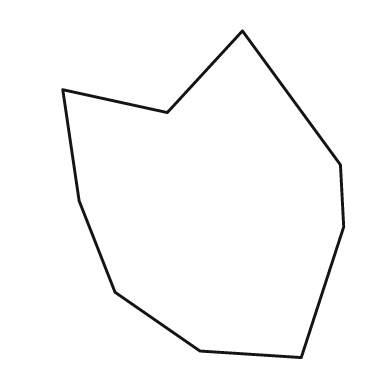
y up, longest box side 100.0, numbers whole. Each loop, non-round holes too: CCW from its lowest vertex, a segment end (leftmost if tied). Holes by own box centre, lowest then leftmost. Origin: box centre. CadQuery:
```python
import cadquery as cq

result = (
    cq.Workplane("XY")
    .moveTo(30.0, -50.0)
    .lineTo(43.0, -10.0)
    .lineTo(42.0, 9.0)
    .lineTo(12.0, 50.0)
    .lineTo(-11.0, 25.0)
    .lineTo(-43.0, 32.0)
    .lineTo(-38.0, -2.0)
    .lineTo(-27.0, -30.0)
    .lineTo(-1.0, -48.0)
    .close()
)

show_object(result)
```